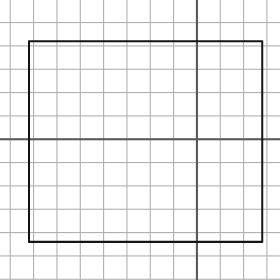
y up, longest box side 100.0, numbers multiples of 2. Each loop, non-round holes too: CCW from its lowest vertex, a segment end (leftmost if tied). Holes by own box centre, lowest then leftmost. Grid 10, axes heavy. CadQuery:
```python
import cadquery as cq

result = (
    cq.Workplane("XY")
    .moveTo(-72.0, -44.0)
    .lineTo(28.0, -44.0)
    .lineTo(28.0, 42.0)
    .lineTo(-72.0, 42.0)
    .close()
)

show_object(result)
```